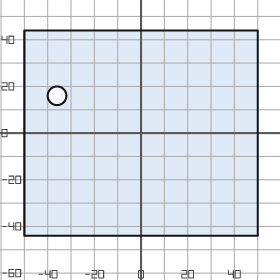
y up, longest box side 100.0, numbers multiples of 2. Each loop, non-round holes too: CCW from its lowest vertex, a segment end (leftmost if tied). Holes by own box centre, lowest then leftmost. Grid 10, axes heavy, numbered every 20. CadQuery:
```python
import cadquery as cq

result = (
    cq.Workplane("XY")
    .moveTo(-50.0, -44.0)
    .lineTo(50.0, -44.0)
    .lineTo(50.0, 44.0)
    .lineTo(-50.0, 44.0)
    .close()
    .moveTo(-36.0, 16.0)
    .circle(4.0)
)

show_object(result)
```